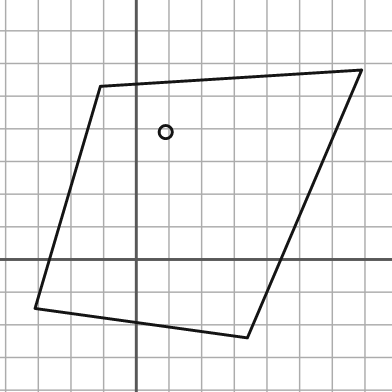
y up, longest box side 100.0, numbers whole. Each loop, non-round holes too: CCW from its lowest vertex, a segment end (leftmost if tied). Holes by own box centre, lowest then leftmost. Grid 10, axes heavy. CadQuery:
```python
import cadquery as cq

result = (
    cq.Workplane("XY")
    .moveTo(34.0, -24.0)
    .lineTo(69.0, 58.0)
    .lineTo(-11.0, 53.0)
    .lineTo(-31.0, -15.0)
    .close()
    .moveTo(9.0, 39.0)
    .circle(2.0)
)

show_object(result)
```